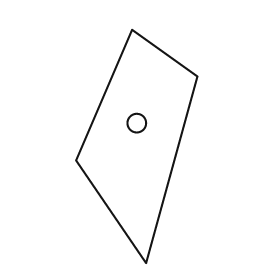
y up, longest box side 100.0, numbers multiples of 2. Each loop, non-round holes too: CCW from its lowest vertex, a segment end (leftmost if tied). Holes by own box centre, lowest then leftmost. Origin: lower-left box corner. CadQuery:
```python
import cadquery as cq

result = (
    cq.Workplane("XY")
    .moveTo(30.0, 0.0)
    .lineTo(52.0, 80.0)
    .lineTo(24.0, 100.0)
    .lineTo(0.0, 44.0)
    .close()
    .moveTo(26.0, 60.0)
    .circle(4.0)
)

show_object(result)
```